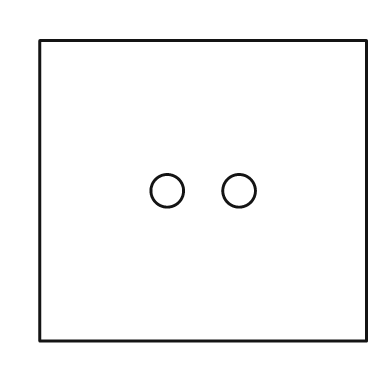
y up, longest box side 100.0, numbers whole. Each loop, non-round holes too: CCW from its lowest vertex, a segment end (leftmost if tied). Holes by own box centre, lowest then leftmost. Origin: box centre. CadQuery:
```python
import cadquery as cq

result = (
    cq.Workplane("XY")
    .moveTo(-50.0, -46.0)
    .lineTo(50.0, -46.0)
    .lineTo(50.0, 46.0)
    .lineTo(-50.0, 46.0)
    .close()
    .moveTo(-11.0, 0.0)
    .circle(5.0)
    .moveTo(11.0, 0.0)
    .circle(5.0)
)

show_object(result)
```